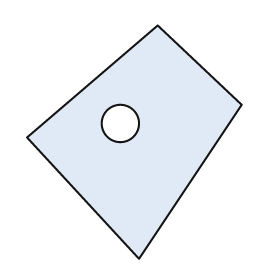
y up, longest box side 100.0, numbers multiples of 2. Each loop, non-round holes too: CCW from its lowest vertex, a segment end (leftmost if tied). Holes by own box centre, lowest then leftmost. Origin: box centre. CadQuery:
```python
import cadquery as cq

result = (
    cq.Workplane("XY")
    .moveTo(2.0, -50.0)
    .lineTo(46.0, 16.0)
    .lineTo(10.0, 50.0)
    .lineTo(-46.0, 2.0)
    .close()
    .moveTo(-6.0, 8.0)
    .circle(8.0)
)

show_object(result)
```